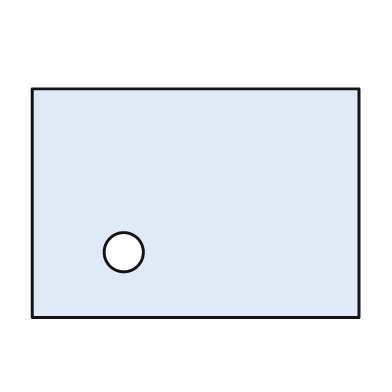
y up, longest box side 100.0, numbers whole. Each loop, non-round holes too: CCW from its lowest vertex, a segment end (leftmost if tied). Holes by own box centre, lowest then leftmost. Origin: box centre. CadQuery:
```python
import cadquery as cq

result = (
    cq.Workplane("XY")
    .moveTo(-50.0, -35.0)
    .lineTo(50.0, -35.0)
    .lineTo(50.0, 35.0)
    .lineTo(-50.0, 35.0)
    .close()
    .moveTo(-22.0, -15.0)
    .circle(6.0)
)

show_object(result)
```